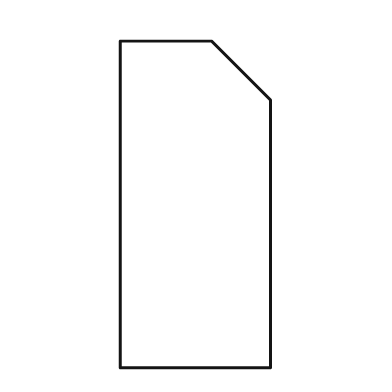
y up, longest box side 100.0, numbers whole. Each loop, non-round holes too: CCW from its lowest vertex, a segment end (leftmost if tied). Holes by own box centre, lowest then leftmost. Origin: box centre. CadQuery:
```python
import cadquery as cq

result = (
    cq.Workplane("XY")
    .moveTo(-23.0, -50.0)
    .lineTo(23.0, -50.0)
    .lineTo(23.0, 32.0)
    .lineTo(5.0, 50.0)
    .lineTo(-23.0, 50.0)
    .close()
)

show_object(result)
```